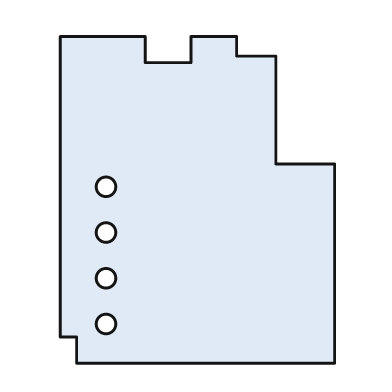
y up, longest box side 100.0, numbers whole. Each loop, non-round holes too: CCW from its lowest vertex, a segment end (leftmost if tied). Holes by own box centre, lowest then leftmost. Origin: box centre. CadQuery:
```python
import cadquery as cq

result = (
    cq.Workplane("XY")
    .moveTo(-37.0, -50.0)
    .lineTo(42.0, -50.0)
    .lineTo(42.0, 11.0)
    .lineTo(24.0, 11.0)
    .lineTo(24.0, 44.0)
    .lineTo(12.0, 44.0)
    .lineTo(12.0, 50.0)
    .lineTo(-2.0, 50.0)
    .lineTo(-2.0, 42.0)
    .lineTo(-16.0, 42.0)
    .lineTo(-16.0, 50.0)
    .lineTo(-42.0, 50.0)
    .lineTo(-42.0, -42.0)
    .lineTo(-37.0, -42.0)
    .close()
    .moveTo(-28.0, -38.0)
    .circle(3.0)
    .moveTo(-28.0, -24.0)
    .circle(3.0)
    .moveTo(-28.0, -10.0)
    .circle(3.0)
    .moveTo(-28.0, 4.0)
    .circle(3.0)
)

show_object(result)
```